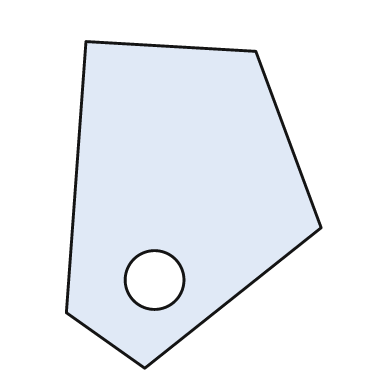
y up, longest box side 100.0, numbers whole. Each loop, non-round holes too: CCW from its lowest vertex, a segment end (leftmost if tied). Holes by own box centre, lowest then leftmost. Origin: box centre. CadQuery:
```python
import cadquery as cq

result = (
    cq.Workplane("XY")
    .moveTo(-15.0, -50.0)
    .lineTo(39.0, -7.0)
    .lineTo(19.0, 47.0)
    .lineTo(-33.0, 50.0)
    .lineTo(-39.0, -33.0)
    .close()
    .moveTo(-12.0, -23.0)
    .circle(9.0)
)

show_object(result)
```